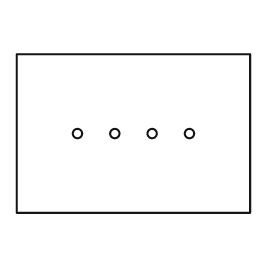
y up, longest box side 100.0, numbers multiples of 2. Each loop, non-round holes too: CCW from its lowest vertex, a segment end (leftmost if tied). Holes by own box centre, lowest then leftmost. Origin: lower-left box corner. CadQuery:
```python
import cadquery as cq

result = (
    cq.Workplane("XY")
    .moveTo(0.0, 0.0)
    .lineTo(100.0, 0.0)
    .lineTo(100.0, 68.0)
    .lineTo(0.0, 68.0)
    .close()
    .moveTo(26.0, 34.0)
    .circle(2.0)
    .moveTo(42.0, 34.0)
    .circle(2.0)
    .moveTo(58.0, 34.0)
    .circle(2.0)
    .moveTo(74.0, 34.0)
    .circle(2.0)
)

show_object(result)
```